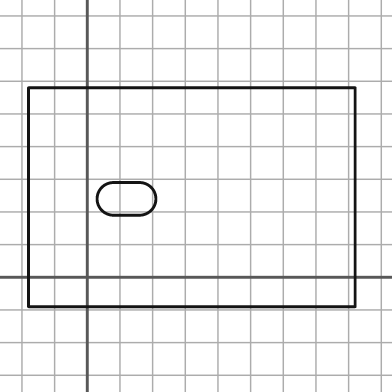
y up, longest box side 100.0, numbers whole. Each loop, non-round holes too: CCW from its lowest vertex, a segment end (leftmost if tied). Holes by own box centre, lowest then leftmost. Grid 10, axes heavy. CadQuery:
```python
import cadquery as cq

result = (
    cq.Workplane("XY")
    .moveTo(-18.0, -9.0)
    .lineTo(82.0, -9.0)
    .lineTo(82.0, 58.0)
    .lineTo(-18.0, 58.0)
    .close()
    .moveTo(8.0, 19.0)
    .lineTo(16.0, 19.0)
    .threePointArc((21.0, 24.0), (16.0, 29.0))
    .lineTo(8.0, 29.0)
    .threePointArc((3.0, 24.0), (8.0, 19.0))
    .close()
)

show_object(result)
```